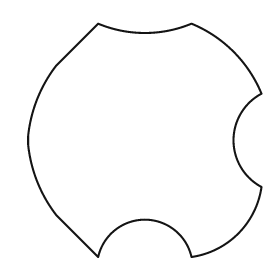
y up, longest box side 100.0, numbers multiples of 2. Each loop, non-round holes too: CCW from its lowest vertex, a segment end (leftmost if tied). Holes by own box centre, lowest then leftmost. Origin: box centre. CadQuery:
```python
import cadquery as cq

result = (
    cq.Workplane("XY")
    .moveTo(-20.0, -50.0)
    .threePointArc((0.0, -34.0), (20.0, -50.0))
    .threePointArc((40.0, -40.0), (50.0, -20.0))
    .threePointArc((38.0, 0.0), (50.0, 20.0))
    .threePointArc((38.0, 38.0), (20.0, 50.0))
    .threePointArc((0.0, 46.0), (-20.0, 50.0))
    .lineTo(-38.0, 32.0)
    .threePointArc((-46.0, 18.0), (-50.0, 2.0))
    .lineTo(-50.0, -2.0)
    .threePointArc((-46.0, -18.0), (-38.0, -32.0))
    .close()
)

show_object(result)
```